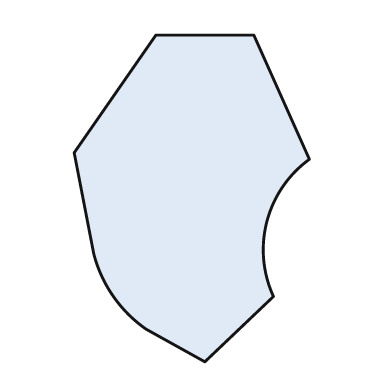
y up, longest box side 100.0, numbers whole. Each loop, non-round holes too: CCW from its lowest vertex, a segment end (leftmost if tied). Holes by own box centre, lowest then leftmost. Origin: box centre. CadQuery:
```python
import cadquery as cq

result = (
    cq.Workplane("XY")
    .moveTo(4.0, -50.0)
    .lineTo(25.0, -30.0)
    .threePointArc((23.0, -7.0), (36.0, 12.0))
    .lineTo(19.0, 50.0)
    .lineTo(-11.0, 50.0)
    .lineTo(-36.0, 14.0)
    .lineTo(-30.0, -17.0)
    .threePointArc((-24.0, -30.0), (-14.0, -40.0))
    .close()
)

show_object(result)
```